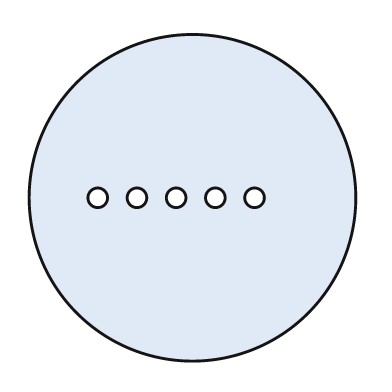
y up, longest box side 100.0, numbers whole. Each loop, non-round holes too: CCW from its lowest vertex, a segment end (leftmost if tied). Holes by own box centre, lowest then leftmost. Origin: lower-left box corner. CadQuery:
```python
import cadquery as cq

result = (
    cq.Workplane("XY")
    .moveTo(50.0, 50.0)
    .circle(50.0)
    .moveTo(21.0, 50.0)
    .circle(3.0)
    .moveTo(33.0, 50.0)
    .circle(3.0)
    .moveTo(45.0, 50.0)
    .circle(3.0)
    .moveTo(57.0, 50.0)
    .circle(3.0)
    .moveTo(69.0, 50.0)
    .circle(3.0)
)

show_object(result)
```